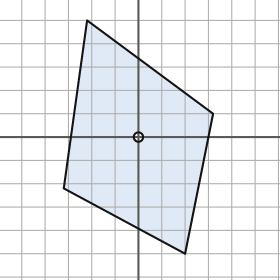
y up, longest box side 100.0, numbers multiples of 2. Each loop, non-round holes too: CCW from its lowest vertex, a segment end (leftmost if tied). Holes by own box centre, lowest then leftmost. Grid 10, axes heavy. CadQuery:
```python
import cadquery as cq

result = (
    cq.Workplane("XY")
    .moveTo(20.0, -50.0)
    .lineTo(32.0, 10.0)
    .lineTo(-22.0, 50.0)
    .lineTo(-32.0, -22.0)
    .close()
    .moveTo(0.0, 0.0)
    .circle(2.0)
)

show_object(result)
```